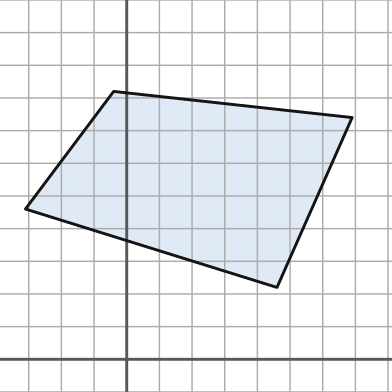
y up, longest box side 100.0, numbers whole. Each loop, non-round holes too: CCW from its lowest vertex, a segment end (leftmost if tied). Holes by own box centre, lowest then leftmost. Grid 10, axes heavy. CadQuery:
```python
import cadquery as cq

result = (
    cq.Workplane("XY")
    .moveTo(46.0, 22.0)
    .lineTo(69.0, 74.0)
    .lineTo(-4.0, 82.0)
    .lineTo(-31.0, 46.0)
    .close()
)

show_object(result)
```